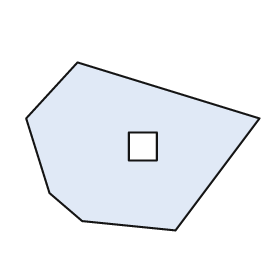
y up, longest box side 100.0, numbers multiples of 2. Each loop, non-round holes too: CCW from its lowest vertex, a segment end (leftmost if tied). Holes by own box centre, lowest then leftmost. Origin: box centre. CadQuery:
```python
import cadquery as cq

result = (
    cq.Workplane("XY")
    .moveTo(14.0, -36.0)
    .lineTo(50.0, 12.0)
    .lineTo(-28.0, 36.0)
    .lineTo(-50.0, 12.0)
    .lineTo(-40.0, -20.0)
    .lineTo(-26.0, -32.0)
    .close()
    .moveTo(-6.0, -6.0)
    .lineTo(6.0, -6.0)
    .lineTo(6.0, 6.0)
    .lineTo(-6.0, 6.0)
    .close()
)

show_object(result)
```